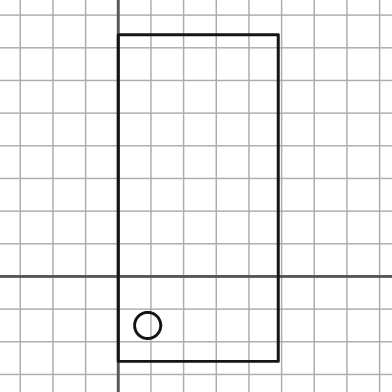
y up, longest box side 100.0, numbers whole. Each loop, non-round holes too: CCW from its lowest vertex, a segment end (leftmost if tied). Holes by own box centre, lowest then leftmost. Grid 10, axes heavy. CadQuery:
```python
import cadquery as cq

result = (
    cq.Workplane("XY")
    .moveTo(0.0, -26.0)
    .lineTo(49.0, -26.0)
    .lineTo(49.0, 74.0)
    .lineTo(0.0, 74.0)
    .close()
    .moveTo(9.0, -15.0)
    .circle(4.0)
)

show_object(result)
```